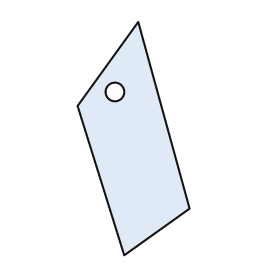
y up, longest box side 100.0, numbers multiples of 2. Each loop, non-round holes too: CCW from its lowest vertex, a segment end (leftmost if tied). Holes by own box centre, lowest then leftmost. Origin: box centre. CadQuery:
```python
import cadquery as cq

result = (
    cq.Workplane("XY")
    .moveTo(-4.0, -50.0)
    .lineTo(24.0, -30.0)
    .lineTo(2.0, 50.0)
    .lineTo(-24.0, 14.0)
    .close()
    .moveTo(-8.0, 20.0)
    .circle(4.0)
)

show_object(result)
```